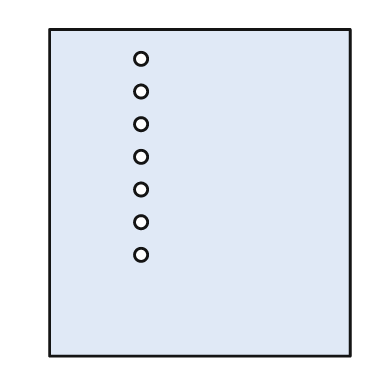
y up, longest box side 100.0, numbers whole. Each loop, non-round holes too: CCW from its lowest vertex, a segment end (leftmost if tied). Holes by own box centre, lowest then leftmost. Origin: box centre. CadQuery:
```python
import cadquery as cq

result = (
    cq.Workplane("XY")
    .moveTo(-46.0, -50.0)
    .lineTo(46.0, -50.0)
    .lineTo(46.0, 50.0)
    .lineTo(-46.0, 50.0)
    .close()
    .moveTo(-18.0, -19.0)
    .circle(2.0)
    .moveTo(-18.0, -9.0)
    .circle(2.0)
    .moveTo(-18.0, 1.0)
    .circle(2.0)
    .moveTo(-18.0, 11.0)
    .circle(2.0)
    .moveTo(-18.0, 21.0)
    .circle(2.0)
    .moveTo(-18.0, 31.0)
    .circle(2.0)
    .moveTo(-18.0, 41.0)
    .circle(2.0)
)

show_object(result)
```